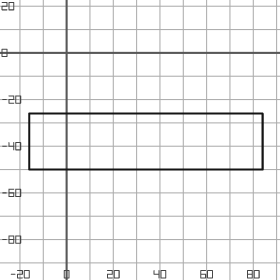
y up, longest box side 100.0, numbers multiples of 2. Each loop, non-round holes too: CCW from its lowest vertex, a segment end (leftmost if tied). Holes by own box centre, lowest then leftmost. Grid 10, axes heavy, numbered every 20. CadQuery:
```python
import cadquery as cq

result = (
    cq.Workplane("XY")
    .moveTo(-16.0, -50.0)
    .lineTo(84.0, -50.0)
    .lineTo(84.0, -26.0)
    .lineTo(-16.0, -26.0)
    .close()
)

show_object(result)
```